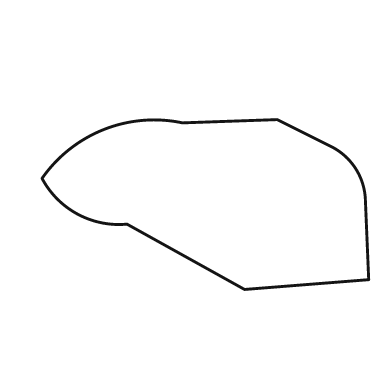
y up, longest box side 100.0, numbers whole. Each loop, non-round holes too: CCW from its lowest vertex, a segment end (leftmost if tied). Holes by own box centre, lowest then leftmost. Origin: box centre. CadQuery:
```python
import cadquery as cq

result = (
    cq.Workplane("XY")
    .moveTo(12.0, -26.0)
    .lineTo(50.0, -23.0)
    .lineTo(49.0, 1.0)
    .threePointArc((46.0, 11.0), (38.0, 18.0))
    .lineTo(22.0, 26.0)
    .lineTo(-7.0, 25.0)
    .threePointArc((-31.0, 23.0), (-50.0, 8.0))
    .threePointArc((-39.0, -3.0), (-24.0, -6.0))
    .close()
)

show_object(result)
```